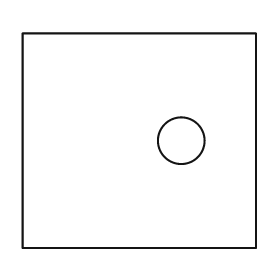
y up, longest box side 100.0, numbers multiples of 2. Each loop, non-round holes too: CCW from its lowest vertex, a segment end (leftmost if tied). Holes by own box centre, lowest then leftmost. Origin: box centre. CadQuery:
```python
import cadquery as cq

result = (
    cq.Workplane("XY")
    .moveTo(-50.0, -46.0)
    .lineTo(50.0, -46.0)
    .lineTo(50.0, 46.0)
    .lineTo(-50.0, 46.0)
    .close()
    .moveTo(18.0, 0.0)
    .circle(10.0)
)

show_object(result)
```